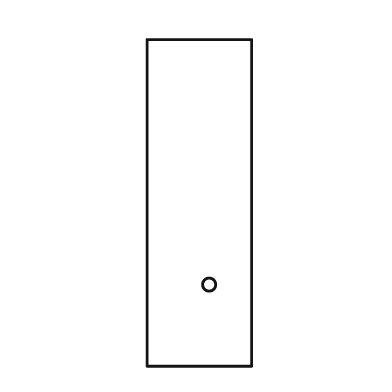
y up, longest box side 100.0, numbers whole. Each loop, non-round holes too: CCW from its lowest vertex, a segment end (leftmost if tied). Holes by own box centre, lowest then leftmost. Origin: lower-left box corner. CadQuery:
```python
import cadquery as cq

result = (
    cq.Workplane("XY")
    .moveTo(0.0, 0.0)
    .lineTo(32.0, 0.0)
    .lineTo(32.0, 100.0)
    .lineTo(0.0, 100.0)
    .close()
    .moveTo(19.0, 25.0)
    .circle(2.0)
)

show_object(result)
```